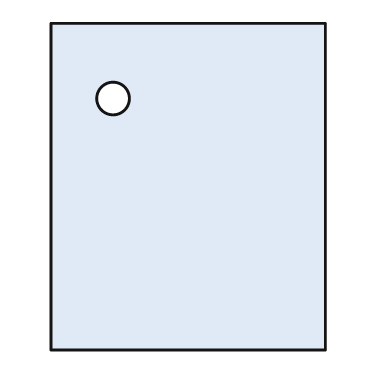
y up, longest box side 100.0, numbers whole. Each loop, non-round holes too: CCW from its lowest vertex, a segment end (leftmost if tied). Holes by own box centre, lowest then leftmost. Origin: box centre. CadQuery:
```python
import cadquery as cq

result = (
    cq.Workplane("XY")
    .moveTo(-42.0, -50.0)
    .lineTo(42.0, -50.0)
    .lineTo(42.0, 50.0)
    .lineTo(-42.0, 50.0)
    .close()
    .moveTo(-23.0, 27.0)
    .circle(5.0)
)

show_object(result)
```